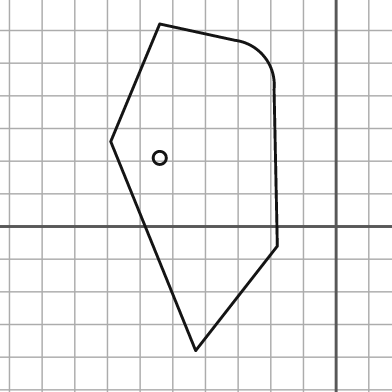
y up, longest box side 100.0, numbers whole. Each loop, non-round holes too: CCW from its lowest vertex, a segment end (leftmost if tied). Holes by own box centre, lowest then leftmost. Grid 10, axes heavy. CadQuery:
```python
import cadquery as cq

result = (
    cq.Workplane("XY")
    .moveTo(-43.0, -38.0)
    .lineTo(-18.0, -6.0)
    .lineTo(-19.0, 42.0)
    .threePointArc((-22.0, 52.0), (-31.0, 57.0))
    .lineTo(-54.0, 62.0)
    .lineTo(-69.0, 26.0)
    .close()
    .moveTo(-54.0, 21.0)
    .circle(2.0)
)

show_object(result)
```